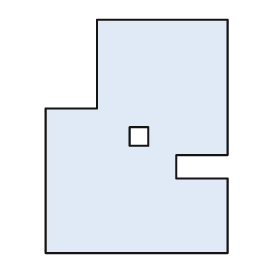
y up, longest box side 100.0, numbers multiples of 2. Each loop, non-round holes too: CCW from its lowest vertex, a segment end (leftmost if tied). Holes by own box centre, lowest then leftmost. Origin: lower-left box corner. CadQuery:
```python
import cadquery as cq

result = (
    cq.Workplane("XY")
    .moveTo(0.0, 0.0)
    .lineTo(78.0, 0.0)
    .lineTo(78.0, 32.0)
    .lineTo(56.0, 32.0)
    .lineTo(56.0, 42.0)
    .lineTo(78.0, 42.0)
    .lineTo(78.0, 100.0)
    .lineTo(22.0, 100.0)
    .lineTo(22.0, 62.0)
    .lineTo(0.0, 62.0)
    .close()
    .moveTo(36.0, 46.0)
    .lineTo(44.0, 46.0)
    .lineTo(44.0, 54.0)
    .lineTo(36.0, 54.0)
    .close()
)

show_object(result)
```